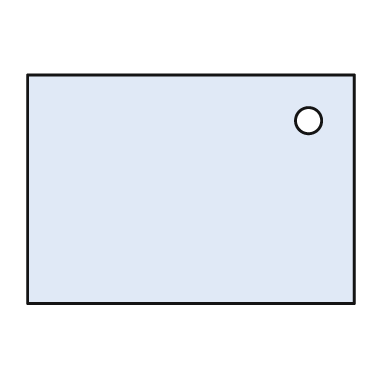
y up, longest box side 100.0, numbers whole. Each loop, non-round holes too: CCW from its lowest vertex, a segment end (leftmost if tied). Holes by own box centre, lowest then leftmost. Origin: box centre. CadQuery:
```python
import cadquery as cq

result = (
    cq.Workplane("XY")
    .moveTo(-50.0, -35.0)
    .lineTo(50.0, -35.0)
    .lineTo(50.0, 35.0)
    .lineTo(-50.0, 35.0)
    .close()
    .moveTo(36.0, 21.0)
    .circle(4.0)
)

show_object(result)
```